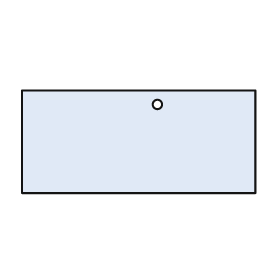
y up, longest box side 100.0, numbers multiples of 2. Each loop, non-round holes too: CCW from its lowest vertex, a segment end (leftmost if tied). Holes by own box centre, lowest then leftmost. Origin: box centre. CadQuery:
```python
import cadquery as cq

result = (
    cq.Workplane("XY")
    .moveTo(-50.0, -22.0)
    .lineTo(50.0, -22.0)
    .lineTo(50.0, 22.0)
    .lineTo(-50.0, 22.0)
    .close()
    .moveTo(8.0, 16.0)
    .circle(2.0)
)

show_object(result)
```